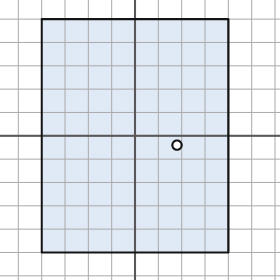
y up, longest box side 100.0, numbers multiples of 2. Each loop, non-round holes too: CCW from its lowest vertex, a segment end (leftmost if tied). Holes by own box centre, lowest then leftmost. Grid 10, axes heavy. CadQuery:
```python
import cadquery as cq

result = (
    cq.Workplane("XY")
    .moveTo(-40.0, -50.0)
    .lineTo(40.0, -50.0)
    .lineTo(40.0, 50.0)
    .lineTo(-40.0, 50.0)
    .close()
    .moveTo(18.0, -4.0)
    .circle(2.0)
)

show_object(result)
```